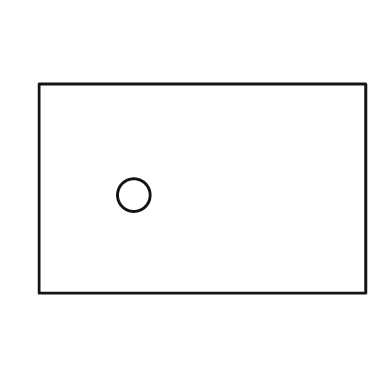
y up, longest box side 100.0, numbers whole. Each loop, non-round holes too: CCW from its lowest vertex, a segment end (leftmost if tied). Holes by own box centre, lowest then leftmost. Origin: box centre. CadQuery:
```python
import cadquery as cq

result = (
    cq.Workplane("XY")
    .moveTo(-50.0, -32.0)
    .lineTo(50.0, -32.0)
    .lineTo(50.0, 32.0)
    .lineTo(-50.0, 32.0)
    .close()
    .moveTo(-21.0, -2.0)
    .circle(5.0)
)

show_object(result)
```